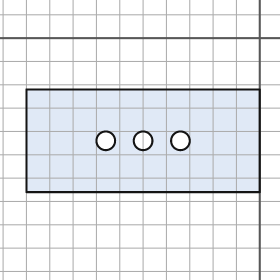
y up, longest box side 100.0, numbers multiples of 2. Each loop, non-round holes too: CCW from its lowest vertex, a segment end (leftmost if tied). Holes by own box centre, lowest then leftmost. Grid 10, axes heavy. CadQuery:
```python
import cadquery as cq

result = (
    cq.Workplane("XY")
    .moveTo(-100.0, -66.0)
    .lineTo(0.0, -66.0)
    .lineTo(0.0, -22.0)
    .lineTo(-100.0, -22.0)
    .close()
    .moveTo(-66.0, -44.0)
    .circle(4.0)
    .moveTo(-50.0, -44.0)
    .circle(4.0)
    .moveTo(-34.0, -44.0)
    .circle(4.0)
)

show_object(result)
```